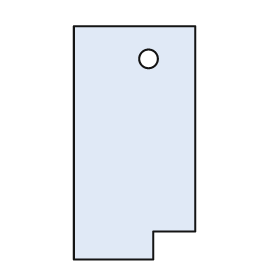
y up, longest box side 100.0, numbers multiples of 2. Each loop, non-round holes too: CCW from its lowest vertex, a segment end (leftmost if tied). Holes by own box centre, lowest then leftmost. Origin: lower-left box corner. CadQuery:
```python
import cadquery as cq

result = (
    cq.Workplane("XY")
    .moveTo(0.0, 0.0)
    .lineTo(34.0, 0.0)
    .lineTo(34.0, 12.0)
    .lineTo(52.0, 12.0)
    .lineTo(52.0, 100.0)
    .lineTo(0.0, 100.0)
    .close()
    .moveTo(32.0, 86.0)
    .circle(4.0)
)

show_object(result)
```